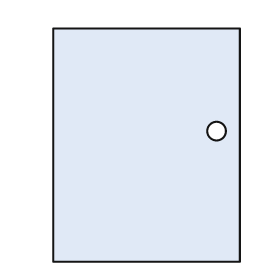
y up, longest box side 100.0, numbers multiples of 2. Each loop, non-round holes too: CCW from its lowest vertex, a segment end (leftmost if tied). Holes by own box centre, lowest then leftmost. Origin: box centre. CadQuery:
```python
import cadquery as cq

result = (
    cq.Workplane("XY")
    .moveTo(-40.0, -50.0)
    .lineTo(40.0, -50.0)
    .lineTo(40.0, 50.0)
    .lineTo(-40.0, 50.0)
    .close()
    .moveTo(30.0, 6.0)
    .circle(4.0)
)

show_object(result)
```